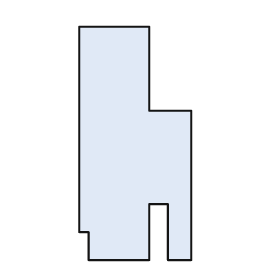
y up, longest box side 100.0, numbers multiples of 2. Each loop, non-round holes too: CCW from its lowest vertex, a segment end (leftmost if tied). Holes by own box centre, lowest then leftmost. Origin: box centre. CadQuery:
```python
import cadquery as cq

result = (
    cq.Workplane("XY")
    .moveTo(-20.0, -50.0)
    .lineTo(6.0, -50.0)
    .lineTo(6.0, -26.0)
    .lineTo(14.0, -26.0)
    .lineTo(14.0, -50.0)
    .lineTo(24.0, -50.0)
    .lineTo(24.0, 14.0)
    .lineTo(6.0, 14.0)
    .lineTo(6.0, 50.0)
    .lineTo(-24.0, 50.0)
    .lineTo(-24.0, -38.0)
    .lineTo(-20.0, -38.0)
    .close()
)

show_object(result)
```